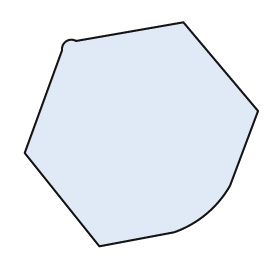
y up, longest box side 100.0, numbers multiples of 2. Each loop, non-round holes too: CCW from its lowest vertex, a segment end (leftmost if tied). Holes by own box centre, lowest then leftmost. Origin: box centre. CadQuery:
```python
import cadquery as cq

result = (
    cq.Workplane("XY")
    .moveTo(-18.0, -48.0)
    .lineTo(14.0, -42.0)
    .threePointArc((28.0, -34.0), (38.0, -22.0))
    .lineTo(50.0, 10.0)
    .lineTo(18.0, 48.0)
    .lineTo(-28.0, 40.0)
    .threePointArc((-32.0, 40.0), (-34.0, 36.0))
    .lineTo(-50.0, -8.0)
    .close()
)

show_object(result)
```